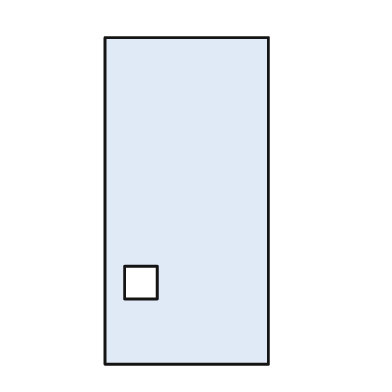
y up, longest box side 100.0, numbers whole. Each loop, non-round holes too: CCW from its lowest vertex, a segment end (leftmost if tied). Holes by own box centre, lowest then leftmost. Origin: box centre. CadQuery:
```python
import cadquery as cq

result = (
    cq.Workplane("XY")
    .moveTo(-25.0, -50.0)
    .lineTo(25.0, -50.0)
    .lineTo(25.0, 50.0)
    .lineTo(-25.0, 50.0)
    .close()
    .moveTo(-19.0, -30.0)
    .lineTo(-9.0, -30.0)
    .lineTo(-9.0, -20.0)
    .lineTo(-19.0, -20.0)
    .close()
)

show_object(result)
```